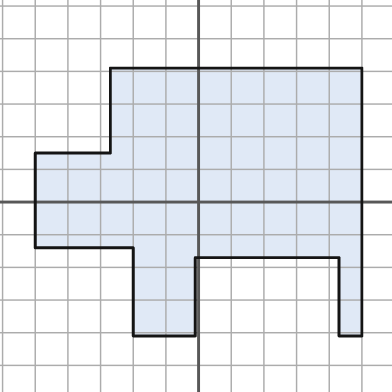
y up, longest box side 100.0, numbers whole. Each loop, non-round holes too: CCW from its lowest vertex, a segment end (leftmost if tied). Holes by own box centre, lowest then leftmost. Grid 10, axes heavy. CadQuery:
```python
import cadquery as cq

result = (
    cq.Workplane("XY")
    .moveTo(-20.0, -41.0)
    .lineTo(-1.0, -41.0)
    .lineTo(-1.0, -17.0)
    .lineTo(43.0, -17.0)
    .lineTo(43.0, -41.0)
    .lineTo(50.0, -41.0)
    .lineTo(50.0, 41.0)
    .lineTo(-27.0, 41.0)
    .lineTo(-27.0, 15.0)
    .lineTo(-50.0, 15.0)
    .lineTo(-50.0, -14.0)
    .lineTo(-20.0, -14.0)
    .close()
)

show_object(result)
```